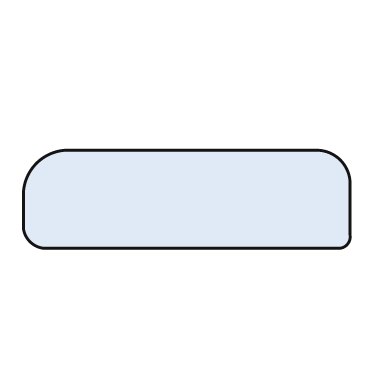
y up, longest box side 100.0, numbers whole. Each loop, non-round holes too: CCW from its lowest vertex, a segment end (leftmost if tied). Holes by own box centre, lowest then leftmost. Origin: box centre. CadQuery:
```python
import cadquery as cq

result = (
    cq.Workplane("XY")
    .moveTo(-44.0, -15.0)
    .lineTo(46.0, -15.0)
    .threePointArc((49.0, -14.0), (50.0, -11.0))
    .lineTo(50.0, 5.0)
    .threePointArc((47.0, 12.0), (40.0, 15.0))
    .lineTo(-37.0, 15.0)
    .threePointArc((-46.0, 11.0), (-50.0, 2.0))
    .lineTo(-50.0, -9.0)
    .threePointArc((-48.0, -13.0), (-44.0, -15.0))
    .close()
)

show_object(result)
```